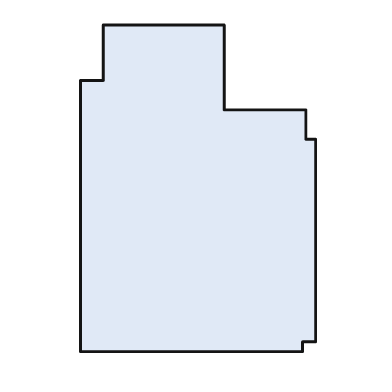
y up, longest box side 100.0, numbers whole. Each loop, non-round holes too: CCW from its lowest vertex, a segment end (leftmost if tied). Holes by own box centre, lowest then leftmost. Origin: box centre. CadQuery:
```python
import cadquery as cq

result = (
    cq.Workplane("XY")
    .moveTo(-36.0, -50.0)
    .lineTo(32.0, -50.0)
    .lineTo(32.0, -47.0)
    .lineTo(36.0, -47.0)
    .lineTo(36.0, 15.0)
    .lineTo(33.0, 15.0)
    .lineTo(33.0, 24.0)
    .lineTo(8.0, 24.0)
    .lineTo(8.0, 50.0)
    .lineTo(-29.0, 50.0)
    .lineTo(-29.0, 33.0)
    .lineTo(-36.0, 33.0)
    .close()
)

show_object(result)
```